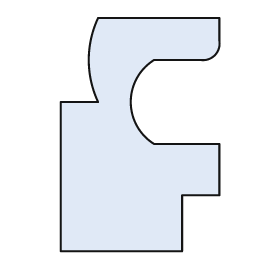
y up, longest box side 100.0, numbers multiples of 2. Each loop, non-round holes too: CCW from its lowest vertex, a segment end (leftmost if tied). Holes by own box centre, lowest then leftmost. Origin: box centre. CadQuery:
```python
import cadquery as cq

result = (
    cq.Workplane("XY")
    .moveTo(-34.0, -50.0)
    .lineTo(18.0, -50.0)
    .lineTo(18.0, -26.0)
    .lineTo(34.0, -26.0)
    .lineTo(34.0, -4.0)
    .lineTo(6.0, -4.0)
    .threePointArc((-4.0, 14.0), (6.0, 32.0))
    .lineTo(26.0, 32.0)
    .threePointArc((32.0, 34.0), (34.0, 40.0))
    .lineTo(34.0, 50.0)
    .lineTo(-18.0, 50.0)
    .threePointArc((-22.0, 32.0), (-18.0, 14.0))
    .lineTo(-34.0, 14.0)
    .close()
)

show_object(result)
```